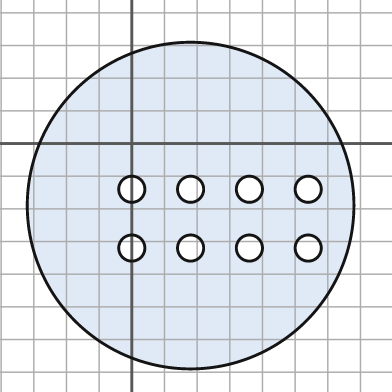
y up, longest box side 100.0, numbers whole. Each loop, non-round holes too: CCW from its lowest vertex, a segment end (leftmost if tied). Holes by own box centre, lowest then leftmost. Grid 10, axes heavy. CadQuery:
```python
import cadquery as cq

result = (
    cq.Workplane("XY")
    .moveTo(18.0, -19.0)
    .circle(50.0)
    .moveTo(0.0, -32.0)
    .circle(4.0)
    .moveTo(18.0, -32.0)
    .circle(4.0)
    .moveTo(36.0, -32.0)
    .circle(4.0)
    .moveTo(54.0, -32.0)
    .circle(4.0)
    .moveTo(0.0, -14.0)
    .circle(4.0)
    .moveTo(18.0, -14.0)
    .circle(4.0)
    .moveTo(36.0, -14.0)
    .circle(4.0)
    .moveTo(54.0, -14.0)
    .circle(4.0)
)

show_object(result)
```